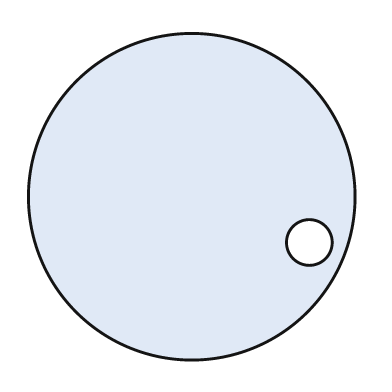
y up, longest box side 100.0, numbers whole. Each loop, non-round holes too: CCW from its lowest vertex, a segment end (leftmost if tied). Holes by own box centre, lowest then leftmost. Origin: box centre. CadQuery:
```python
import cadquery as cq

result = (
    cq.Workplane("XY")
    .moveTo(0.0, 0.0)
    .circle(50.0)
    .moveTo(36.0, -14.0)
    .circle(7.0)
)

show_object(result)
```